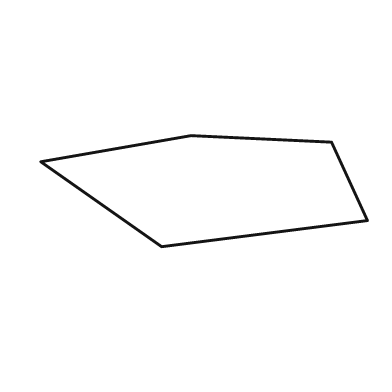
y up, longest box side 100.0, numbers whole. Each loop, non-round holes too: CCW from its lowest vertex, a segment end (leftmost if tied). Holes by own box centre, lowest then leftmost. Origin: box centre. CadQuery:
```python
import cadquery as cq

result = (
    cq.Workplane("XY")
    .moveTo(-13.0, -17.0)
    .lineTo(50.0, -9.0)
    .lineTo(39.0, 15.0)
    .lineTo(-4.0, 17.0)
    .lineTo(-50.0, 9.0)
    .close()
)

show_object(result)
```